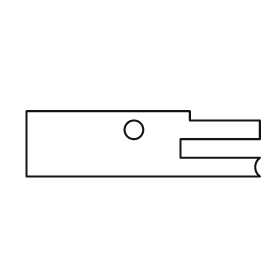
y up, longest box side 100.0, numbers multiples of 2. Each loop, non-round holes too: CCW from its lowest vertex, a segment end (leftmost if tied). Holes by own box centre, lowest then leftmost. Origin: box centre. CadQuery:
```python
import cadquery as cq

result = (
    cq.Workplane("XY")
    .moveTo(-50.0, -14.0)
    .lineTo(50.0, -14.0)
    .threePointArc((48.0, -10.0), (50.0, -6.0))
    .lineTo(16.0, -6.0)
    .lineTo(16.0, 2.0)
    .lineTo(50.0, 2.0)
    .lineTo(50.0, 10.0)
    .lineTo(20.0, 10.0)
    .lineTo(20.0, 14.0)
    .lineTo(-50.0, 14.0)
    .close()
    .moveTo(-4.0, 6.0)
    .circle(4.0)
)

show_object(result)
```